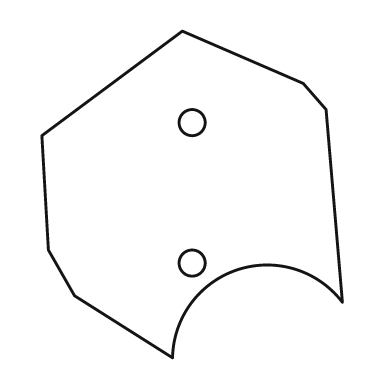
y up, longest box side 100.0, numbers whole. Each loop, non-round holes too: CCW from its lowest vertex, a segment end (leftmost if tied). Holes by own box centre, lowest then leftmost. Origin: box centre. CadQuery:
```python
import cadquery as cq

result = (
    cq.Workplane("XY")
    .moveTo(-6.0, -50.0)
    .threePointArc((14.0, -23.0), (46.0, -33.0))
    .lineTo(41.0, 26.0)
    .lineTo(34.0, 34.0)
    .lineTo(-3.0, 50.0)
    .lineTo(-46.0, 18.0)
    .lineTo(-44.0, -17.0)
    .lineTo(-36.0, -31.0)
    .close()
    .moveTo(0.0, -21.0)
    .circle(4.0)
    .moveTo(0.0, 22.0)
    .circle(4.0)
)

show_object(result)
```